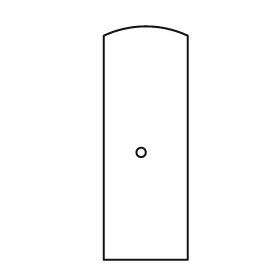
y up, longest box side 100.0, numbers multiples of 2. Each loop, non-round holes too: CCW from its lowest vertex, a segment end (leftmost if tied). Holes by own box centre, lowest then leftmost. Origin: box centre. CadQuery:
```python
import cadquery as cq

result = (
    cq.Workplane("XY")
    .moveTo(-18.0, -50.0)
    .lineTo(18.0, -50.0)
    .lineTo(18.0, 46.0)
    .threePointArc((0.0, 50.0), (-18.0, 46.0))
    .close()
    .moveTo(-2.0, -4.0)
    .circle(2.0)
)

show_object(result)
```